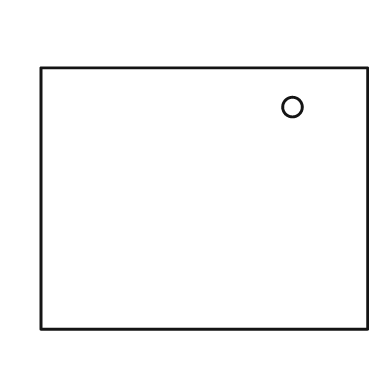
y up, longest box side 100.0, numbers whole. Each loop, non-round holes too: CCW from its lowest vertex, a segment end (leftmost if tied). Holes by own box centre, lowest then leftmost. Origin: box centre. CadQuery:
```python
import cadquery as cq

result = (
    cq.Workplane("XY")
    .moveTo(-50.0, -40.0)
    .lineTo(50.0, -40.0)
    .lineTo(50.0, 40.0)
    .lineTo(-50.0, 40.0)
    .close()
    .moveTo(27.0, 28.0)
    .circle(3.0)
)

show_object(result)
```